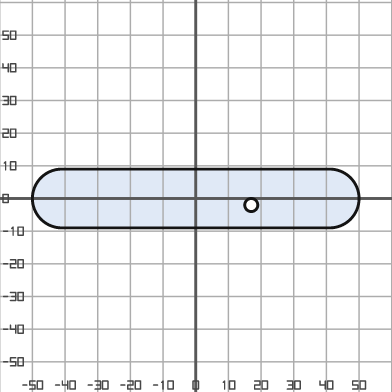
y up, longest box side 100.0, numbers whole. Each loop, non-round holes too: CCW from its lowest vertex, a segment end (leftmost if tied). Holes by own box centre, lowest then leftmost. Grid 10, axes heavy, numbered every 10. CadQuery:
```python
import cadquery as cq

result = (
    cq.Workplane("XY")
    .moveTo(-41.0, -9.0)
    .lineTo(41.0, -9.0)
    .threePointArc((50.0, 0.0), (41.0, 9.0))
    .lineTo(-41.0, 9.0)
    .threePointArc((-50.0, 0.0), (-41.0, -9.0))
    .close()
    .moveTo(17.0, -2.0)
    .circle(2.0)
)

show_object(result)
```